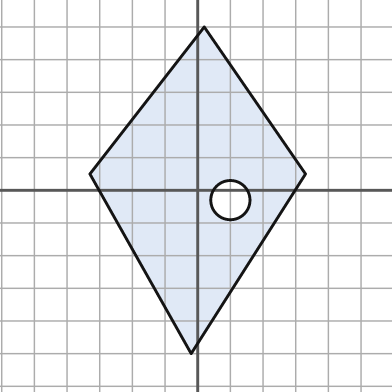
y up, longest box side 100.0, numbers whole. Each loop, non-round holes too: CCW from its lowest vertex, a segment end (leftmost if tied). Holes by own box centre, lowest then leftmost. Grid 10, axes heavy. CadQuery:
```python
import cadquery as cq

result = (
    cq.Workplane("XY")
    .moveTo(-2.0, -50.0)
    .lineTo(33.0, 5.0)
    .lineTo(2.0, 50.0)
    .lineTo(-33.0, 5.0)
    .close()
    .moveTo(10.0, -3.0)
    .circle(6.0)
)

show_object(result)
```